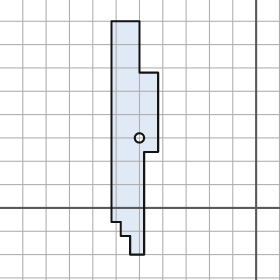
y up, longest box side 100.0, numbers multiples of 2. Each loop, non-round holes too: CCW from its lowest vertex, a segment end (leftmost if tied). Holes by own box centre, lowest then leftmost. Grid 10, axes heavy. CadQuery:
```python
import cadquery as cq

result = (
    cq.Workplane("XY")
    .moveTo(-54.0, -20.0)
    .lineTo(-48.0, -20.0)
    .lineTo(-48.0, 24.0)
    .lineTo(-42.0, 24.0)
    .lineTo(-42.0, 58.0)
    .lineTo(-50.0, 58.0)
    .lineTo(-50.0, 80.0)
    .lineTo(-62.0, 80.0)
    .lineTo(-62.0, -6.0)
    .lineTo(-58.0, -6.0)
    .lineTo(-58.0, -12.0)
    .lineTo(-54.0, -12.0)
    .close()
    .moveTo(-50.0, 30.0)
    .circle(2.0)
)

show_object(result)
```